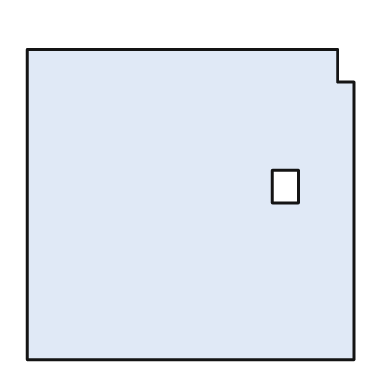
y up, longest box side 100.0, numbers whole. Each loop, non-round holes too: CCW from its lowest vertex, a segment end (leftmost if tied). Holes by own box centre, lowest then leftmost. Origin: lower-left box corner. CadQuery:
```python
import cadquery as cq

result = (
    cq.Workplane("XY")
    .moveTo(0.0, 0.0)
    .lineTo(100.0, 0.0)
    .lineTo(100.0, 85.0)
    .lineTo(95.0, 85.0)
    .lineTo(95.0, 95.0)
    .lineTo(0.0, 95.0)
    .close()
    .moveTo(75.0, 48.0)
    .lineTo(83.0, 48.0)
    .lineTo(83.0, 58.0)
    .lineTo(75.0, 58.0)
    .close()
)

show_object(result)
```